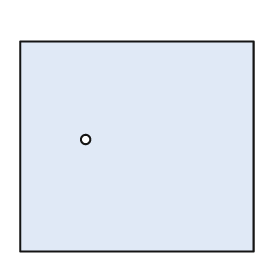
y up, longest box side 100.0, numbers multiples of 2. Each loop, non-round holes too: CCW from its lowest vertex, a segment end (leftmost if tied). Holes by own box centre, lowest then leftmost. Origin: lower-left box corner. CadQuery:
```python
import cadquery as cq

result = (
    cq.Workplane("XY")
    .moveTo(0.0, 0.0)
    .lineTo(100.0, 0.0)
    .lineTo(100.0, 90.0)
    .lineTo(0.0, 90.0)
    .close()
    .moveTo(28.0, 48.0)
    .circle(2.0)
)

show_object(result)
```